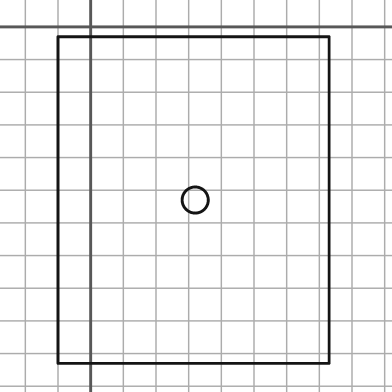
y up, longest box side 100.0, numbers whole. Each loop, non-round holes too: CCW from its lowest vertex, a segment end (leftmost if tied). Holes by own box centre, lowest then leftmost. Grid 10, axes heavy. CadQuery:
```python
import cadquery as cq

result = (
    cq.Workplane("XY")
    .moveTo(-10.0, -103.0)
    .lineTo(73.0, -103.0)
    .lineTo(73.0, -3.0)
    .lineTo(-10.0, -3.0)
    .close()
    .moveTo(32.0, -53.0)
    .circle(4.0)
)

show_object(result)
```